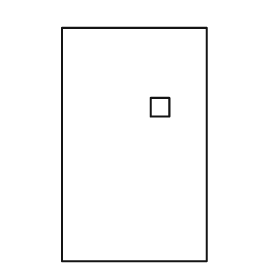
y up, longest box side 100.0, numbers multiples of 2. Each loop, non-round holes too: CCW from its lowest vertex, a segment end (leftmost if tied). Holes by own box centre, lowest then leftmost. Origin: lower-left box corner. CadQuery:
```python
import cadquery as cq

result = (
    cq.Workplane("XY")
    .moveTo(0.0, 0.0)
    .lineTo(62.0, 0.0)
    .lineTo(62.0, 100.0)
    .lineTo(0.0, 100.0)
    .close()
    .moveTo(38.0, 62.0)
    .lineTo(46.0, 62.0)
    .lineTo(46.0, 70.0)
    .lineTo(38.0, 70.0)
    .close()
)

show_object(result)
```